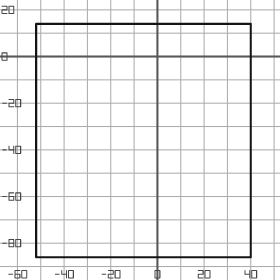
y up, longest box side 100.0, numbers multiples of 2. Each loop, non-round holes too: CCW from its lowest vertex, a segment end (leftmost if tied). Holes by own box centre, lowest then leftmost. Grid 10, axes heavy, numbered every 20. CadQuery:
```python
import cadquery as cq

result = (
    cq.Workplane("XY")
    .moveTo(-52.0, -86.0)
    .lineTo(40.0, -86.0)
    .lineTo(40.0, 14.0)
    .lineTo(-52.0, 14.0)
    .close()
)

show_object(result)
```